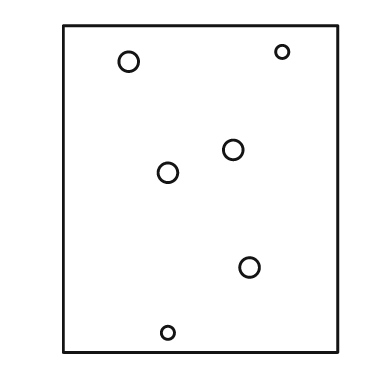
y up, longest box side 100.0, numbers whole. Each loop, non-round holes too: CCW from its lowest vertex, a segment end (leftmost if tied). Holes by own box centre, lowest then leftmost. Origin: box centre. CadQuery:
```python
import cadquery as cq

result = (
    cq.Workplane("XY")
    .moveTo(-42.0, -50.0)
    .lineTo(42.0, -50.0)
    .lineTo(42.0, 50.0)
    .lineTo(-42.0, 50.0)
    .close()
    .moveTo(-10.0, -44.0)
    .circle(2.0)
    .moveTo(15.0, -24.0)
    .circle(3.0)
    .moveTo(-10.0, 5.0)
    .circle(3.0)
    .moveTo(10.0, 12.0)
    .circle(3.0)
    .moveTo(-22.0, 39.0)
    .circle(3.0)
    .moveTo(25.0, 42.0)
    .circle(2.0)
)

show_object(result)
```